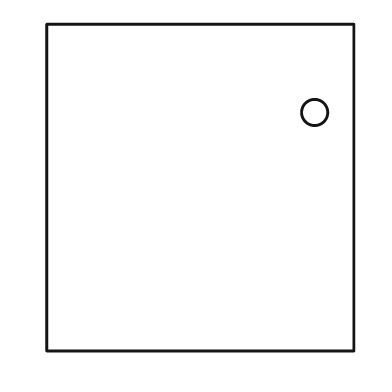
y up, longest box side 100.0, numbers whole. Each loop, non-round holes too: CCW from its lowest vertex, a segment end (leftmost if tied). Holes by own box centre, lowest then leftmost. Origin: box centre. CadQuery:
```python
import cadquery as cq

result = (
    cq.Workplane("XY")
    .moveTo(-47.0, -50.0)
    .lineTo(47.0, -50.0)
    .lineTo(47.0, 50.0)
    .lineTo(-47.0, 50.0)
    .close()
    .moveTo(35.0, 23.0)
    .circle(4.0)
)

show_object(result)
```